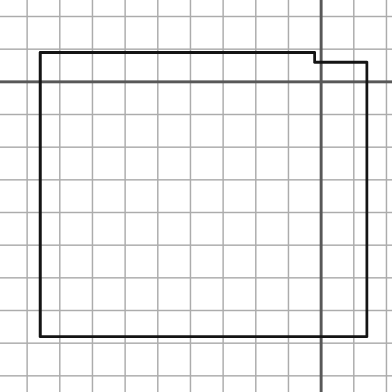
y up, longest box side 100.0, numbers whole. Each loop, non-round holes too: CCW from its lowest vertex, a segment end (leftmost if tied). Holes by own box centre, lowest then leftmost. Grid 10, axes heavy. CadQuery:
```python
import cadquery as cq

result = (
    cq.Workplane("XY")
    .moveTo(-86.0, -78.0)
    .lineTo(14.0, -78.0)
    .lineTo(14.0, 6.0)
    .lineTo(-2.0, 6.0)
    .lineTo(-2.0, 9.0)
    .lineTo(-86.0, 9.0)
    .close()
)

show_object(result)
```